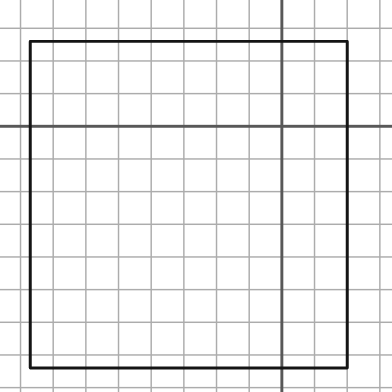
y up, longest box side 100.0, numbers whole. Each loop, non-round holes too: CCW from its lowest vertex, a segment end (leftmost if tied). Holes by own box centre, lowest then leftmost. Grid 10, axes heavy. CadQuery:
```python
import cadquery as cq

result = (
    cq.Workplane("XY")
    .moveTo(-77.0, -74.0)
    .lineTo(20.0, -74.0)
    .lineTo(20.0, 26.0)
    .lineTo(-77.0, 26.0)
    .close()
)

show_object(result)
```